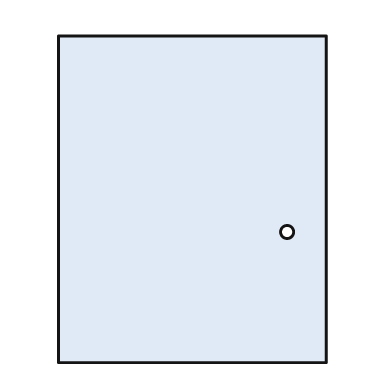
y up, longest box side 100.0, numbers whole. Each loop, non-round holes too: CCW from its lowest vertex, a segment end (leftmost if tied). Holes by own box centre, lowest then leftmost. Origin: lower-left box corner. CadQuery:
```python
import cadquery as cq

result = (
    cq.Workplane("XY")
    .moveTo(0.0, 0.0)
    .lineTo(82.0, 0.0)
    .lineTo(82.0, 100.0)
    .lineTo(0.0, 100.0)
    .close()
    .moveTo(70.0, 40.0)
    .circle(2.0)
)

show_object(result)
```